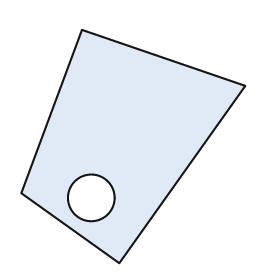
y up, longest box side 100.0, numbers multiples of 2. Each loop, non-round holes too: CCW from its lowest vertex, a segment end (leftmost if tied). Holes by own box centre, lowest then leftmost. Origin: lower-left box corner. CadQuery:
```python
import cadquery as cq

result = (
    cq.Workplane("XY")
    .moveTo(42.0, 0.0)
    .lineTo(96.0, 76.0)
    .lineTo(26.0, 100.0)
    .lineTo(0.0, 30.0)
    .close()
    .moveTo(30.0, 28.0)
    .circle(10.0)
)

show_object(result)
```